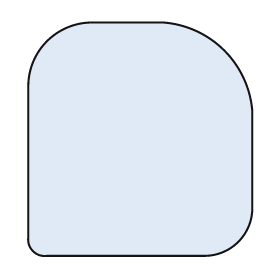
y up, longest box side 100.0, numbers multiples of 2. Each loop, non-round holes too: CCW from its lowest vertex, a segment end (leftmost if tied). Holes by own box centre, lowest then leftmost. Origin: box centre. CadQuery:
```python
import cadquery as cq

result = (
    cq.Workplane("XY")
    .moveTo(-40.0, -50.0)
    .lineTo(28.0, -50.0)
    .threePointArc((42.0, -44.0), (48.0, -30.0))
    .lineTo(48.0, 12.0)
    .threePointArc((36.0, 38.0), (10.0, 50.0))
    .lineTo(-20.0, 50.0)
    .threePointArc((-40.0, 42.0), (-48.0, 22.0))
    .lineTo(-48.0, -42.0)
    .threePointArc((-46.0, -48.0), (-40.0, -50.0))
    .close()
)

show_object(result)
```